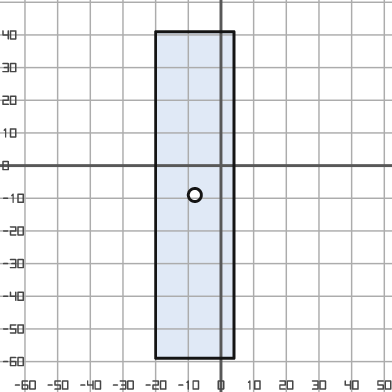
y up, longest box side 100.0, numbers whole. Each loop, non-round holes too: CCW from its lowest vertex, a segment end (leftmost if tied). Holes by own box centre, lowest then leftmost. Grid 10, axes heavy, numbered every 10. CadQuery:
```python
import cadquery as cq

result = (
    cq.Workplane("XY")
    .moveTo(-20.0, -59.0)
    .lineTo(4.0, -59.0)
    .lineTo(4.0, 41.0)
    .lineTo(-20.0, 41.0)
    .close()
    .moveTo(-8.0, -9.0)
    .circle(2.0)
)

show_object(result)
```